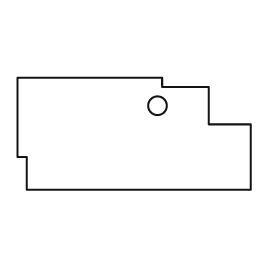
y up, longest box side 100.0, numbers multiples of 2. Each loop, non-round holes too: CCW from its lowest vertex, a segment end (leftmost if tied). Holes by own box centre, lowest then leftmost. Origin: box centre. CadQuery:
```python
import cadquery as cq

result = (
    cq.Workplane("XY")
    .moveTo(-46.0, -24.0)
    .lineTo(50.0, -24.0)
    .lineTo(50.0, 4.0)
    .lineTo(32.0, 4.0)
    .lineTo(32.0, 20.0)
    .lineTo(12.0, 20.0)
    .lineTo(12.0, 24.0)
    .lineTo(-50.0, 24.0)
    .lineTo(-50.0, -10.0)
    .lineTo(-46.0, -10.0)
    .close()
    .moveTo(10.0, 12.0)
    .circle(4.0)
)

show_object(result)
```